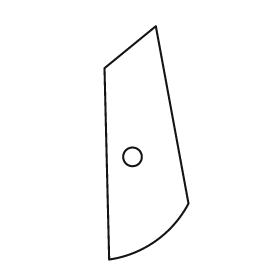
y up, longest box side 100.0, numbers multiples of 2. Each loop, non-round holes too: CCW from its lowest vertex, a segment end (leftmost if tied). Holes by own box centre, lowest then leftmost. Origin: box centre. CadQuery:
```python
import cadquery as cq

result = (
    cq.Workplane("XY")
    .moveTo(-16.0, -50.0)
    .threePointArc((4.0, -42.0), (18.0, -26.0))
    .lineTo(4.0, 50.0)
    .lineTo(-18.0, 32.0)
    .close()
    .moveTo(-6.0, -6.0)
    .circle(4.0)
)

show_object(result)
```